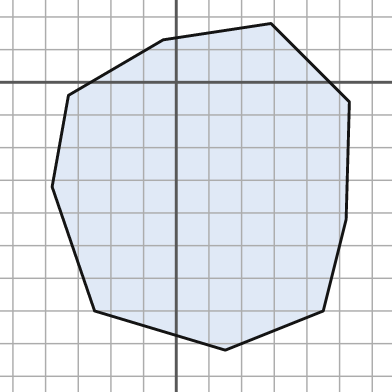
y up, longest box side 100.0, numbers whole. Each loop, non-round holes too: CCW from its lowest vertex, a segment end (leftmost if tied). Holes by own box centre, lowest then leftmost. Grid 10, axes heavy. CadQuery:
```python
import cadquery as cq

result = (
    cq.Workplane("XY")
    .moveTo(15.0, -82.0)
    .lineTo(45.0, -70.0)
    .lineTo(52.0, -42.0)
    .lineTo(53.0, -6.0)
    .lineTo(29.0, 18.0)
    .lineTo(-4.0, 13.0)
    .lineTo(-33.0, -4.0)
    .lineTo(-38.0, -32.0)
    .lineTo(-25.0, -70.0)
    .close()
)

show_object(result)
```